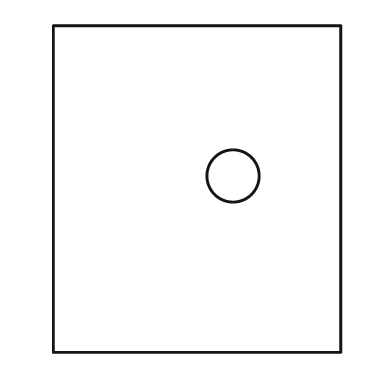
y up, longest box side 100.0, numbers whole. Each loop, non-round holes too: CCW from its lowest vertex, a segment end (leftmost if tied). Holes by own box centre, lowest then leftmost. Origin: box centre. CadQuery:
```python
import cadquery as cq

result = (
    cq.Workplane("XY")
    .moveTo(-44.0, -50.0)
    .lineTo(44.0, -50.0)
    .lineTo(44.0, 50.0)
    .lineTo(-44.0, 50.0)
    .close()
    .moveTo(11.0, 4.0)
    .circle(8.0)
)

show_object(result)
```